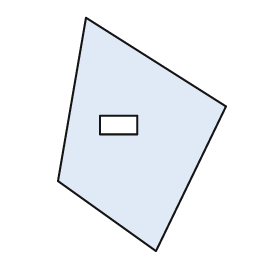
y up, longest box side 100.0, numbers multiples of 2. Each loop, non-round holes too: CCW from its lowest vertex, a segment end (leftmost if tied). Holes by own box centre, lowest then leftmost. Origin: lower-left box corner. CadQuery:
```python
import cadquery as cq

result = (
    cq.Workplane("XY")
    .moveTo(42.0, 0.0)
    .lineTo(72.0, 62.0)
    .lineTo(12.0, 100.0)
    .lineTo(0.0, 30.0)
    .close()
    .moveTo(18.0, 50.0)
    .lineTo(34.0, 50.0)
    .lineTo(34.0, 58.0)
    .lineTo(18.0, 58.0)
    .close()
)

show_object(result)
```